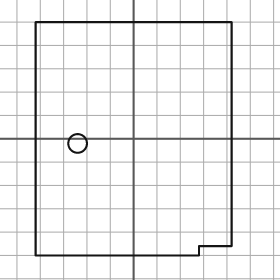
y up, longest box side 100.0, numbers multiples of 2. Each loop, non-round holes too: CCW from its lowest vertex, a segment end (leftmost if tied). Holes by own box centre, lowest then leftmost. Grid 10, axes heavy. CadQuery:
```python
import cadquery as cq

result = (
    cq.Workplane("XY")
    .moveTo(-42.0, -50.0)
    .lineTo(28.0, -50.0)
    .lineTo(28.0, -46.0)
    .lineTo(42.0, -46.0)
    .lineTo(42.0, 50.0)
    .lineTo(-42.0, 50.0)
    .close()
    .moveTo(-24.0, -2.0)
    .circle(4.0)
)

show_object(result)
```